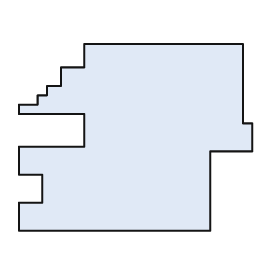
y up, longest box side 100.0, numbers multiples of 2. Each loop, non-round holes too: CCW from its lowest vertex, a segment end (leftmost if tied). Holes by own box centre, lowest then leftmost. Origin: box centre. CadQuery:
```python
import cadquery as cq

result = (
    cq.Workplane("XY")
    .moveTo(-50.0, -40.0)
    .lineTo(32.0, -40.0)
    .lineTo(32.0, -6.0)
    .lineTo(50.0, -6.0)
    .lineTo(50.0, 6.0)
    .lineTo(46.0, 6.0)
    .lineTo(46.0, 40.0)
    .lineTo(-22.0, 40.0)
    .lineTo(-22.0, 30.0)
    .lineTo(-32.0, 30.0)
    .lineTo(-32.0, 22.0)
    .lineTo(-38.0, 22.0)
    .lineTo(-38.0, 18.0)
    .lineTo(-42.0, 18.0)
    .lineTo(-42.0, 14.0)
    .lineTo(-50.0, 14.0)
    .lineTo(-50.0, 10.0)
    .lineTo(-22.0, 10.0)
    .lineTo(-22.0, -4.0)
    .lineTo(-50.0, -4.0)
    .lineTo(-50.0, -16.0)
    .lineTo(-40.0, -16.0)
    .lineTo(-40.0, -28.0)
    .lineTo(-50.0, -28.0)
    .close()
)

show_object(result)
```